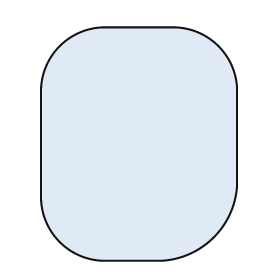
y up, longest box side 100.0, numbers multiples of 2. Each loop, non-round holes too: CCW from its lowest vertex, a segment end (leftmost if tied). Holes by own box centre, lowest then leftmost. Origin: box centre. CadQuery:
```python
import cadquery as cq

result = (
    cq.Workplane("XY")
    .moveTo(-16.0, -50.0)
    .lineTo(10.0, -50.0)
    .threePointArc((32.0, -40.0), (42.0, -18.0))
    .lineTo(42.0, 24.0)
    .threePointArc((34.0, 42.0), (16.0, 50.0))
    .lineTo(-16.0, 50.0)
    .threePointArc((-34.0, 42.0), (-42.0, 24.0))
    .lineTo(-42.0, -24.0)
    .threePointArc((-34.0, -42.0), (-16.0, -50.0))
    .close()
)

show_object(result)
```